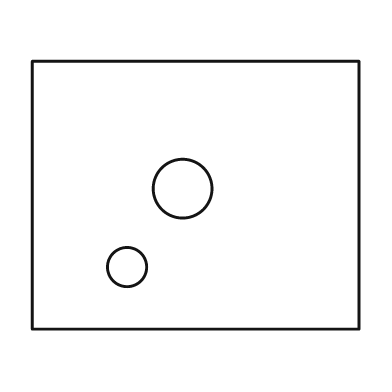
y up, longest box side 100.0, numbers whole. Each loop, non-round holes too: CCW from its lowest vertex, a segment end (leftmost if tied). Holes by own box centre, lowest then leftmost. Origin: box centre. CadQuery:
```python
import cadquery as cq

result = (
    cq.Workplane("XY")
    .moveTo(-50.0, -41.0)
    .lineTo(50.0, -41.0)
    .lineTo(50.0, 41.0)
    .lineTo(-50.0, 41.0)
    .close()
    .moveTo(-21.0, -22.0)
    .circle(6.0)
    .moveTo(-4.0, 2.0)
    .circle(9.0)
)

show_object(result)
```